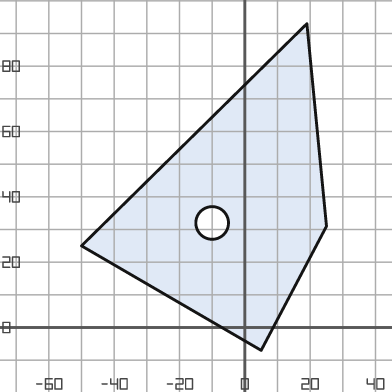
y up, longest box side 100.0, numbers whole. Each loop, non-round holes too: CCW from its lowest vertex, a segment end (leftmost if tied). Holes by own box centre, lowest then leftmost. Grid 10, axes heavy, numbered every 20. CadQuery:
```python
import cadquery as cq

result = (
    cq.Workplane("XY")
    .moveTo(5.0, -7.0)
    .lineTo(25.0, 31.0)
    .lineTo(19.0, 93.0)
    .lineTo(-50.0, 25.0)
    .close()
    .moveTo(-10.0, 32.0)
    .circle(5.0)
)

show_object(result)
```